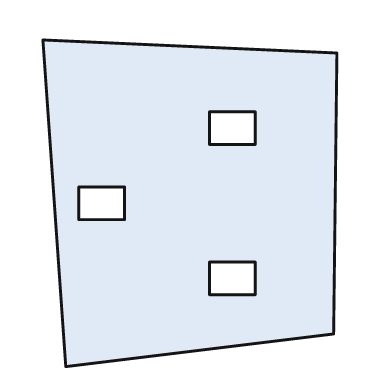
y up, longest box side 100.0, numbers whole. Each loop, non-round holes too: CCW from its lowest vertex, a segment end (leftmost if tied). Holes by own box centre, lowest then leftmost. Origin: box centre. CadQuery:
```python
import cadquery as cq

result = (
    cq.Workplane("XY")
    .moveTo(-38.0, -50.0)
    .lineTo(44.0, -40.0)
    .lineTo(45.0, 46.0)
    .lineTo(-45.0, 50.0)
    .close()
    .moveTo(6.0, -28.0)
    .lineTo(20.0, -28.0)
    .lineTo(20.0, -18.0)
    .lineTo(6.0, -18.0)
    .close()
    .moveTo(-34.0, -5.0)
    .lineTo(-20.0, -5.0)
    .lineTo(-20.0, 5.0)
    .lineTo(-34.0, 5.0)
    .close()
    .moveTo(6.0, 18.0)
    .lineTo(20.0, 18.0)
    .lineTo(20.0, 28.0)
    .lineTo(6.0, 28.0)
    .close()
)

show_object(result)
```